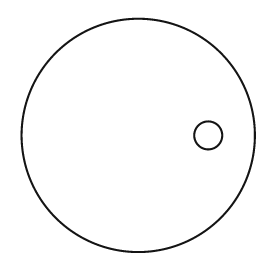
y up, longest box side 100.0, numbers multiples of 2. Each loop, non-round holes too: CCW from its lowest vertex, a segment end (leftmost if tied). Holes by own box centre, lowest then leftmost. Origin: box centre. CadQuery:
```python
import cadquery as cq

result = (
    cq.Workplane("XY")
    .moveTo(0.0, 0.0)
    .circle(50.0)
    .moveTo(30.0, 0.0)
    .circle(6.0)
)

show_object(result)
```